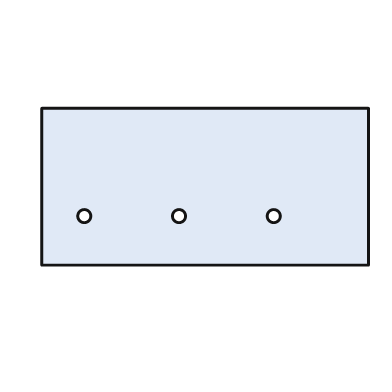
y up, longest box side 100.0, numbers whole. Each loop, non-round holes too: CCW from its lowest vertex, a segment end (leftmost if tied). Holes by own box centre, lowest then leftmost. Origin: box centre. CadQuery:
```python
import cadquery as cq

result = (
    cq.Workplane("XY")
    .moveTo(-50.0, -24.0)
    .lineTo(50.0, -24.0)
    .lineTo(50.0, 24.0)
    .lineTo(-50.0, 24.0)
    .close()
    .moveTo(-37.0, -9.0)
    .circle(2.0)
    .moveTo(-8.0, -9.0)
    .circle(2.0)
    .moveTo(21.0, -9.0)
    .circle(2.0)
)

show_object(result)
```